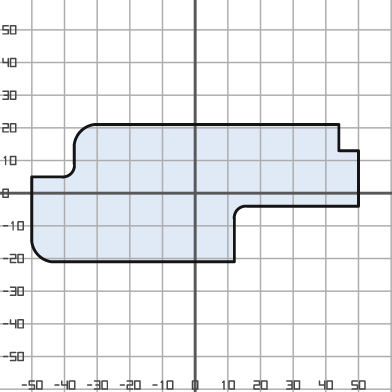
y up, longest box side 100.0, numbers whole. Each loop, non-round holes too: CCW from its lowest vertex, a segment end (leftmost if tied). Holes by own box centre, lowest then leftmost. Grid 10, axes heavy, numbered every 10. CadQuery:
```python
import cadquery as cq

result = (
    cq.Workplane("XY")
    .moveTo(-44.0, -21.0)
    .lineTo(12.0, -21.0)
    .lineTo(12.0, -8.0)
    .threePointArc((13.0, -5.0), (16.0, -4.0))
    .lineTo(50.0, -4.0)
    .lineTo(50.0, 13.0)
    .lineTo(44.0, 13.0)
    .lineTo(44.0, 21.0)
    .lineTo(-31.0, 21.0)
    .threePointArc((-35.0, 19.0), (-37.0, 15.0))
    .lineTo(-37.0, 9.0)
    .threePointArc((-38.0, 6.0), (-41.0, 5.0))
    .lineTo(-50.0, 5.0)
    .lineTo(-50.0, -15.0)
    .threePointArc((-48.0, -19.0), (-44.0, -21.0))
    .close()
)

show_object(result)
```